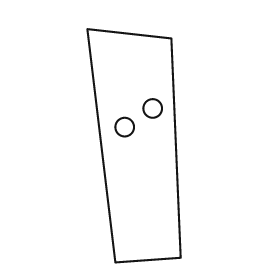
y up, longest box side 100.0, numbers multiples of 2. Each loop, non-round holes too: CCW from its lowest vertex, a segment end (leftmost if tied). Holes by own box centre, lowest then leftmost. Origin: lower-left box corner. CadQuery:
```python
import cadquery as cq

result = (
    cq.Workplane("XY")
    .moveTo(12.0, 0.0)
    .lineTo(40.0, 2.0)
    .lineTo(36.0, 96.0)
    .lineTo(0.0, 100.0)
    .close()
    .moveTo(16.0, 58.0)
    .circle(4.0)
    .moveTo(28.0, 66.0)
    .circle(4.0)
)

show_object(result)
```